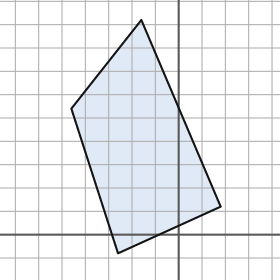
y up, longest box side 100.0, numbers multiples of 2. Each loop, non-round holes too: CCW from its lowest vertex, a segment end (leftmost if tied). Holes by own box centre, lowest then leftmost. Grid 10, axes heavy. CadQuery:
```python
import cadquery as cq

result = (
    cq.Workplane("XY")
    .moveTo(-26.0, -8.0)
    .lineTo(18.0, 12.0)
    .lineTo(-16.0, 92.0)
    .lineTo(-46.0, 54.0)
    .close()
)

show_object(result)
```